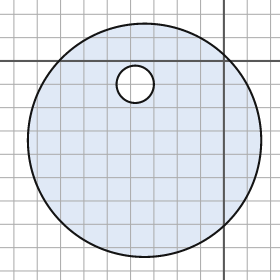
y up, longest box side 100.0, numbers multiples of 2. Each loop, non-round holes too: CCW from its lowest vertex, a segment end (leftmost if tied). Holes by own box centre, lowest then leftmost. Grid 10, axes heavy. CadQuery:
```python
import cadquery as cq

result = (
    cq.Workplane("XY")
    .moveTo(-34.0, -34.0)
    .circle(50.0)
    .moveTo(-38.0, -10.0)
    .circle(8.0)
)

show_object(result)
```